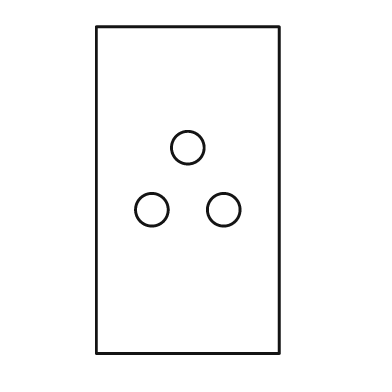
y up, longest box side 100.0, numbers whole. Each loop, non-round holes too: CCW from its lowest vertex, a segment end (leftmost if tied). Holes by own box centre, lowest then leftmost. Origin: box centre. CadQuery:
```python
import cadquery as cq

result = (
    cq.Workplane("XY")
    .moveTo(-28.0, -50.0)
    .lineTo(28.0, -50.0)
    .lineTo(28.0, 50.0)
    .lineTo(-28.0, 50.0)
    .close()
    .moveTo(-11.0, -6.0)
    .circle(5.0)
    .moveTo(11.0, -6.0)
    .circle(5.0)
    .moveTo(0.0, 13.0)
    .circle(5.0)
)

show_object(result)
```